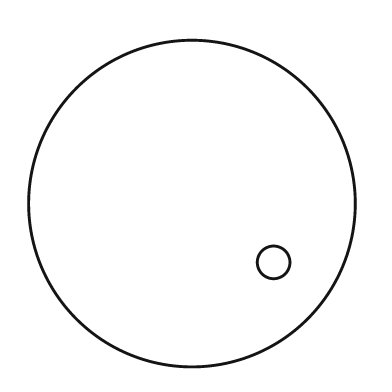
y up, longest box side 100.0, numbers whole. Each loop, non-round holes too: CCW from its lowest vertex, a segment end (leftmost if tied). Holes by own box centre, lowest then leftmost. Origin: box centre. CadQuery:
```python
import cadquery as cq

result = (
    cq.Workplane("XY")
    .moveTo(0.0, 0.0)
    .circle(50.0)
    .moveTo(25.0, -18.0)
    .circle(5.0)
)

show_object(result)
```